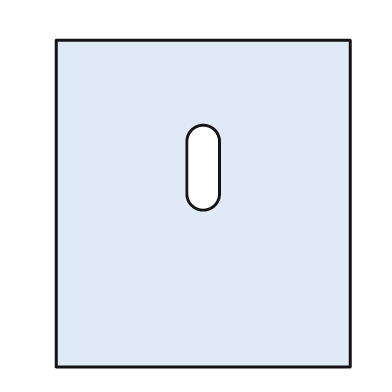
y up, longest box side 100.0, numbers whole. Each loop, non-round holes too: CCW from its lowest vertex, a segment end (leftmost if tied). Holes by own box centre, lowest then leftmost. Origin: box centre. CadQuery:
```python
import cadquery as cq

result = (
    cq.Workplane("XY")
    .moveTo(-45.0, -50.0)
    .lineTo(45.0, -50.0)
    .lineTo(45.0, 50.0)
    .lineTo(-45.0, 50.0)
    .close()
    .moveTo(-5.0, 3.0)
    .threePointArc((0.0, -2.0), (5.0, 3.0))
    .lineTo(5.0, 19.0)
    .threePointArc((0.0, 24.0), (-5.0, 19.0))
    .close()
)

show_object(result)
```